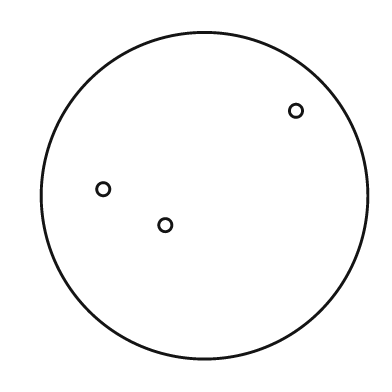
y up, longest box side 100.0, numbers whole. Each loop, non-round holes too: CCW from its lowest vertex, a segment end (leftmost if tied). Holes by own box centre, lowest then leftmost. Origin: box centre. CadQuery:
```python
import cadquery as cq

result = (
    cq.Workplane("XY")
    .moveTo(0.0, 0.0)
    .circle(50.0)
    .moveTo(-12.0, -9.0)
    .circle(2.0)
    .moveTo(-31.0, 2.0)
    .circle(2.0)
    .moveTo(28.0, 26.0)
    .circle(2.0)
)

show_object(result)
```